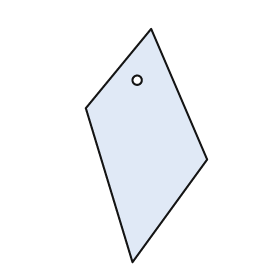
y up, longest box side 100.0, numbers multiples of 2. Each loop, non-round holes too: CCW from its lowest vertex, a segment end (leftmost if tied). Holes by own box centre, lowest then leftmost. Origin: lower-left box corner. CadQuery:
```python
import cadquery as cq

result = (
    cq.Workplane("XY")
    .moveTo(20.0, 0.0)
    .lineTo(52.0, 44.0)
    .lineTo(28.0, 100.0)
    .lineTo(0.0, 66.0)
    .close()
    .moveTo(22.0, 78.0)
    .circle(2.0)
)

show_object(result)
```